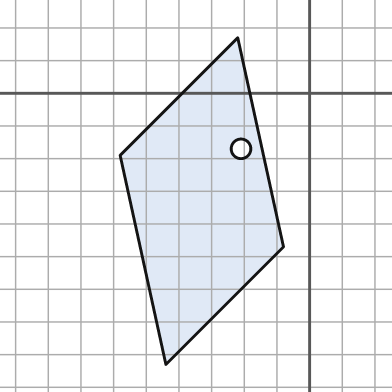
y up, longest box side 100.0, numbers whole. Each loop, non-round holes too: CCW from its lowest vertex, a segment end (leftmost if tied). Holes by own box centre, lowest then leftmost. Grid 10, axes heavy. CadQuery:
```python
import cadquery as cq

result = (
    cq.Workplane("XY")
    .moveTo(-44.0, -83.0)
    .lineTo(-8.0, -47.0)
    .lineTo(-22.0, 17.0)
    .lineTo(-58.0, -19.0)
    .close()
    .moveTo(-21.0, -17.0)
    .circle(3.0)
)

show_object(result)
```